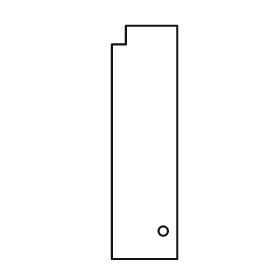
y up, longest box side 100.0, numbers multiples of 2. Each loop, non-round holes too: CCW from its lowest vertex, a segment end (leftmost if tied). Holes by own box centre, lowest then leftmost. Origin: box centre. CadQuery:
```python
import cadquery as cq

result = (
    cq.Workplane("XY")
    .moveTo(-14.0, -50.0)
    .lineTo(14.0, -50.0)
    .lineTo(14.0, 50.0)
    .lineTo(-8.0, 50.0)
    .lineTo(-8.0, 42.0)
    .lineTo(-14.0, 42.0)
    .close()
    .moveTo(8.0, -38.0)
    .circle(2.0)
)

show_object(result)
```